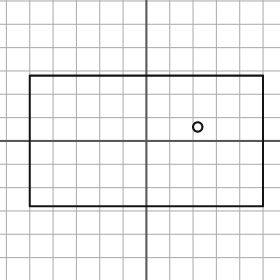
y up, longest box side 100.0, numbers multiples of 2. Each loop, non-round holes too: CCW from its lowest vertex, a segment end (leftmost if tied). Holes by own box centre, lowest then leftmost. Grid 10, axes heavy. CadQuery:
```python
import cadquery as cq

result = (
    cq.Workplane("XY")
    .moveTo(-50.0, -28.0)
    .lineTo(50.0, -28.0)
    .lineTo(50.0, 28.0)
    .lineTo(-50.0, 28.0)
    .close()
    .moveTo(22.0, 6.0)
    .circle(2.0)
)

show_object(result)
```